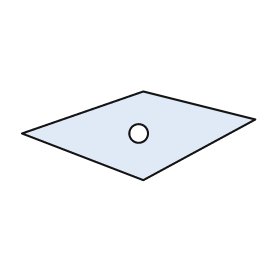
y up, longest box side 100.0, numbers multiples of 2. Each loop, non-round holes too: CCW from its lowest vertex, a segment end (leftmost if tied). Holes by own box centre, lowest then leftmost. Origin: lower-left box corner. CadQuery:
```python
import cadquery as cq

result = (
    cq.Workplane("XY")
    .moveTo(52.0, 0.0)
    .lineTo(100.0, 26.0)
    .lineTo(52.0, 38.0)
    .lineTo(0.0, 20.0)
    .close()
    .moveTo(50.0, 20.0)
    .circle(4.0)
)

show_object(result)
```